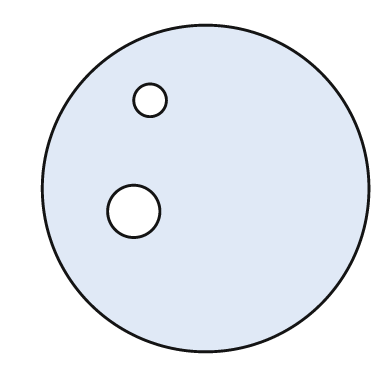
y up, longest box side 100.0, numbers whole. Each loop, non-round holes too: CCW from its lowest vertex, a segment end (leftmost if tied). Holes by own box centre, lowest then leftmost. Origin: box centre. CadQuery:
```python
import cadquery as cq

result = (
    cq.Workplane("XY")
    .moveTo(0.0, 0.0)
    .circle(50.0)
    .moveTo(-22.0, -7.0)
    .circle(8.0)
    .moveTo(-17.0, 27.0)
    .circle(5.0)
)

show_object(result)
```